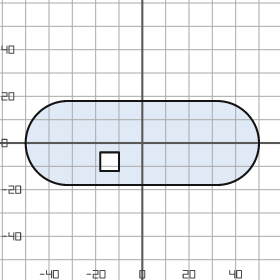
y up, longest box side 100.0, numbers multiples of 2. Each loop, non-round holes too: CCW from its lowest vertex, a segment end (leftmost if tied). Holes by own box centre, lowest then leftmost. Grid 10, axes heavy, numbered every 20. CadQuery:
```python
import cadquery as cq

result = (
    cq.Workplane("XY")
    .moveTo(-32.0, -18.0)
    .lineTo(32.0, -18.0)
    .threePointArc((50.0, 0.0), (32.0, 18.0))
    .lineTo(-32.0, 18.0)
    .threePointArc((-50.0, 0.0), (-32.0, -18.0))
    .close()
    .moveTo(-18.0, -12.0)
    .lineTo(-10.0, -12.0)
    .lineTo(-10.0, -4.0)
    .lineTo(-18.0, -4.0)
    .close()
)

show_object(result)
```